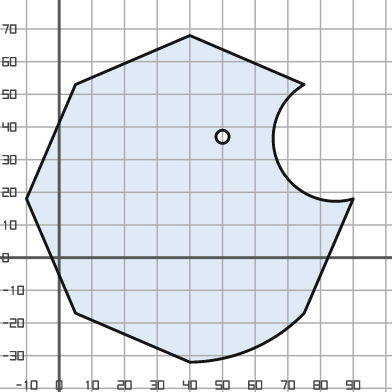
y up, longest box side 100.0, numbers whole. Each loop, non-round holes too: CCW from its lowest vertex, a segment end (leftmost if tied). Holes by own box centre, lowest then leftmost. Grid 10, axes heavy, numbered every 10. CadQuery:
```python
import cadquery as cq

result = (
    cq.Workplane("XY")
    .moveTo(40.0, -32.0)
    .threePointArc((59.0, -28.0), (75.0, -17.0))
    .lineTo(90.0, 18.0)
    .threePointArc((67.0, 29.0), (75.0, 53.0))
    .lineTo(40.0, 68.0)
    .lineTo(5.0, 53.0)
    .lineTo(-10.0, 18.0)
    .lineTo(5.0, -17.0)
    .close()
    .moveTo(50.0, 37.0)
    .circle(2.0)
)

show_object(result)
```